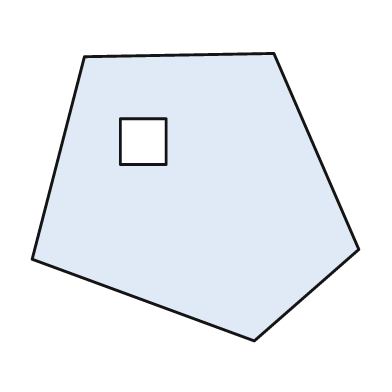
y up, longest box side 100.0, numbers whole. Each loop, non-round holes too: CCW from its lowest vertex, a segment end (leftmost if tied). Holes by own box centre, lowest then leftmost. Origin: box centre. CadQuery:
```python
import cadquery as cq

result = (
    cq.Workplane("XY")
    .moveTo(18.0, -44.0)
    .lineTo(50.0, -16.0)
    .lineTo(24.0, 44.0)
    .lineTo(-34.0, 43.0)
    .lineTo(-50.0, -19.0)
    .close()
    .moveTo(-23.0, 10.0)
    .lineTo(-9.0, 10.0)
    .lineTo(-9.0, 24.0)
    .lineTo(-23.0, 24.0)
    .close()
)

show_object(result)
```